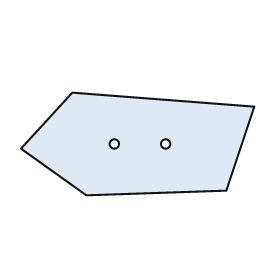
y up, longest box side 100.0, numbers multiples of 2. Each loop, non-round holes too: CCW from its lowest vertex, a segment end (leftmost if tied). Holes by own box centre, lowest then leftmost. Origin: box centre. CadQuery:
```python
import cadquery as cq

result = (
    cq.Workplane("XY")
    .moveTo(-22.0, -22.0)
    .lineTo(38.0, -20.0)
    .lineTo(50.0, 16.0)
    .lineTo(-28.0, 22.0)
    .lineTo(-50.0, -2.0)
    .close()
    .moveTo(-10.0, 0.0)
    .circle(2.0)
    .moveTo(12.0, 0.0)
    .circle(2.0)
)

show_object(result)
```